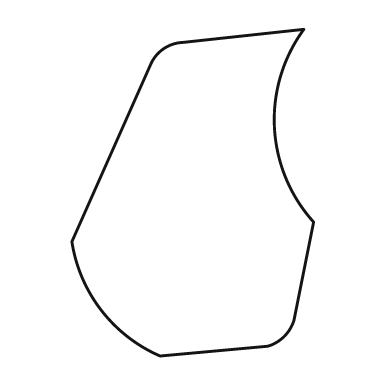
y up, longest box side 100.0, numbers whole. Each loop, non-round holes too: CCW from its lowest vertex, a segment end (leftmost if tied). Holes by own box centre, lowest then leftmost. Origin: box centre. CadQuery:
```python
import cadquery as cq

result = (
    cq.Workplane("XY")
    .moveTo(-10.0, -50.0)
    .lineTo(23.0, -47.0)
    .threePointArc((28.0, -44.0), (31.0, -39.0))
    .lineTo(37.0, -9.0)
    .threePointArc((25.0, 20.0), (34.0, 50.0))
    .lineTo(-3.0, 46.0)
    .threePointArc((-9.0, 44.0), (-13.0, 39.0))
    .lineTo(-37.0, -15.0)
    .threePointArc((-28.0, -36.0), (-10.0, -50.0))
    .close()
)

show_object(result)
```